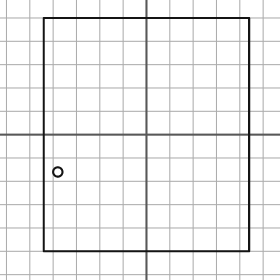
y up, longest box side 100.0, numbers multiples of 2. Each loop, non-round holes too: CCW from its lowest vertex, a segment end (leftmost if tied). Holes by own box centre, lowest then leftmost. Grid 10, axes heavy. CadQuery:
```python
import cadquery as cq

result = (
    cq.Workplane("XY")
    .moveTo(-44.0, -50.0)
    .lineTo(44.0, -50.0)
    .lineTo(44.0, 50.0)
    .lineTo(-44.0, 50.0)
    .close()
    .moveTo(-38.0, -16.0)
    .circle(2.0)
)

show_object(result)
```